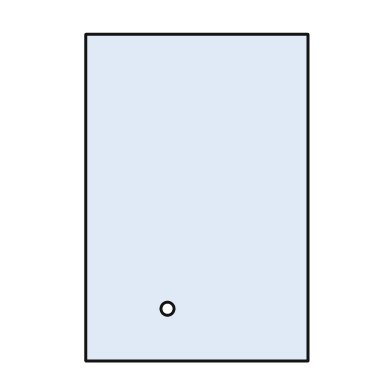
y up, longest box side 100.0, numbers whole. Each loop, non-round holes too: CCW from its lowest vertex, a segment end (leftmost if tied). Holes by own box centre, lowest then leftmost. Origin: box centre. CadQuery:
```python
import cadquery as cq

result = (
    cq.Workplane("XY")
    .moveTo(-34.0, -50.0)
    .lineTo(34.0, -50.0)
    .lineTo(34.0, 50.0)
    .lineTo(-34.0, 50.0)
    .close()
    .moveTo(-9.0, -34.0)
    .circle(2.0)
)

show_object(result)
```